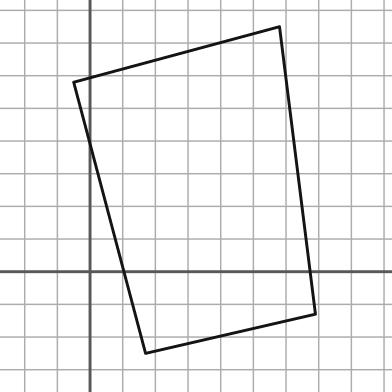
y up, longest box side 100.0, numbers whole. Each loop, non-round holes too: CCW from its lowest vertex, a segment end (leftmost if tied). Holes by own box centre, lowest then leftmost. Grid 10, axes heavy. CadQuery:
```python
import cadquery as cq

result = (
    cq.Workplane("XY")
    .moveTo(17.0, -25.0)
    .lineTo(69.0, -13.0)
    .lineTo(58.0, 75.0)
    .lineTo(-5.0, 58.0)
    .close()
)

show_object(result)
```